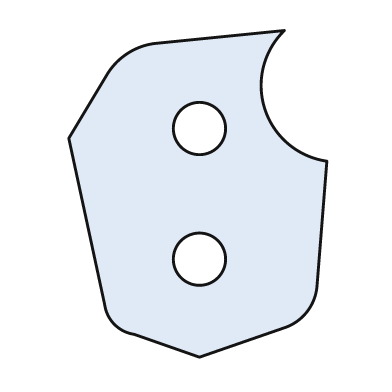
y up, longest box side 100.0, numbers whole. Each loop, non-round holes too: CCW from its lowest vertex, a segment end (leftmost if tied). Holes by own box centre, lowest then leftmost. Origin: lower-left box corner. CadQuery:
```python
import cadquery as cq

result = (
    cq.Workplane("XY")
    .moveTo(40.0, 0.0)
    .lineTo(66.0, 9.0)
    .threePointArc((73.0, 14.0), (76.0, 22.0))
    .lineTo(79.0, 60.0)
    .threePointArc((60.0, 76.0), (66.0, 100.0))
    .lineTo(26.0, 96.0)
    .threePointArc((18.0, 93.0), (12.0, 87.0))
    .lineTo(0.0, 67.0)
    .lineTo(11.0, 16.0)
    .threePointArc((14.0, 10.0), (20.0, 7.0))
    .close()
    .moveTo(40.0, 30.0)
    .circle(8.0)
    .moveTo(40.0, 70.0)
    .circle(8.0)
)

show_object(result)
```